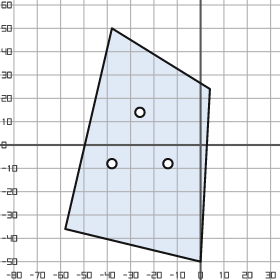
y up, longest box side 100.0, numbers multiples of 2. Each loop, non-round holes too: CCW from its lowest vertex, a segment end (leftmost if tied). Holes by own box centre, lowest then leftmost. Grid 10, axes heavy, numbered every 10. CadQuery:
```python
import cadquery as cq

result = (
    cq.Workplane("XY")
    .moveTo(0.0, -50.0)
    .lineTo(4.0, 24.0)
    .lineTo(-38.0, 50.0)
    .lineTo(-58.0, -36.0)
    .close()
    .moveTo(-38.0, -8.0)
    .circle(2.0)
    .moveTo(-14.0, -8.0)
    .circle(2.0)
    .moveTo(-26.0, 14.0)
    .circle(2.0)
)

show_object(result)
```